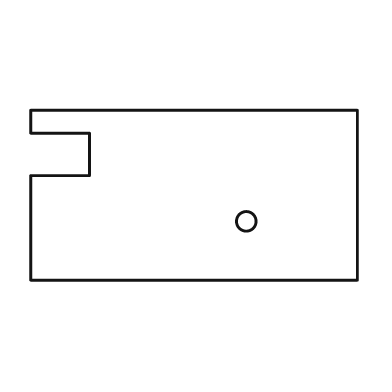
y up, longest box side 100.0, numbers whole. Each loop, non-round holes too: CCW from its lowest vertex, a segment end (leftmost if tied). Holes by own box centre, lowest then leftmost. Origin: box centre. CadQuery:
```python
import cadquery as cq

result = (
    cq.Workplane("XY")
    .moveTo(-50.0, -26.0)
    .lineTo(50.0, -26.0)
    .lineTo(50.0, 26.0)
    .lineTo(-50.0, 26.0)
    .lineTo(-50.0, 19.0)
    .lineTo(-32.0, 19.0)
    .lineTo(-32.0, 6.0)
    .lineTo(-50.0, 6.0)
    .close()
    .moveTo(16.0, -8.0)
    .circle(3.0)
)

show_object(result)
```